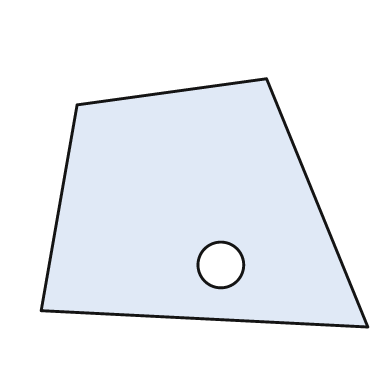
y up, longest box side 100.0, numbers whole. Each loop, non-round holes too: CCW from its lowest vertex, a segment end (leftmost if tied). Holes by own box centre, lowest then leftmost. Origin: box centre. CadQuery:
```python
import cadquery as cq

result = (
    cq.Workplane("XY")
    .moveTo(50.0, -38.0)
    .lineTo(19.0, 38.0)
    .lineTo(-39.0, 30.0)
    .lineTo(-50.0, -33.0)
    .close()
    .moveTo(5.0, -19.0)
    .circle(7.0)
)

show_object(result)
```